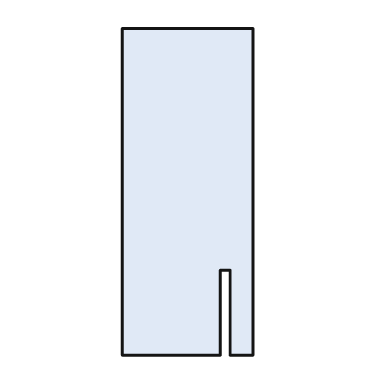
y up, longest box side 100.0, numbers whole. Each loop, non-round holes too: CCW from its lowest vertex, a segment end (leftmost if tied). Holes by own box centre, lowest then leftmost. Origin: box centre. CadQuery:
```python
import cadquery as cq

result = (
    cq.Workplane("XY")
    .moveTo(-20.0, -50.0)
    .lineTo(10.0, -50.0)
    .lineTo(10.0, -24.0)
    .lineTo(13.0, -24.0)
    .lineTo(13.0, -50.0)
    .lineTo(20.0, -50.0)
    .lineTo(20.0, 50.0)
    .lineTo(-20.0, 50.0)
    .close()
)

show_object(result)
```